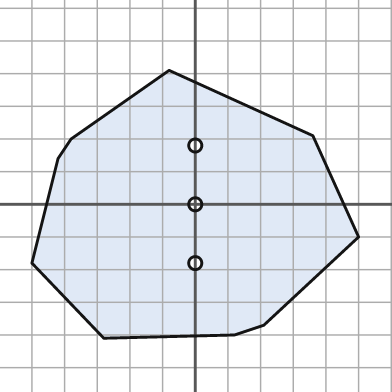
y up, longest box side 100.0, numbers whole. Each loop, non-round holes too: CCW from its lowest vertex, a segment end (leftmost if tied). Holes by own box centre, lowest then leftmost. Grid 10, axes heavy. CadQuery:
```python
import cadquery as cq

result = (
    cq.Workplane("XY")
    .moveTo(-28.0, -41.0)
    .lineTo(12.0, -40.0)
    .lineTo(21.0, -37.0)
    .lineTo(50.0, -10.0)
    .lineTo(36.0, 21.0)
    .lineTo(-8.0, 41.0)
    .lineTo(-38.0, 20.0)
    .lineTo(-42.0, 14.0)
    .lineTo(-50.0, -18.0)
    .close()
    .moveTo(0.0, -18.0)
    .circle(2.0)
    .moveTo(0.0, 0.0)
    .circle(2.0)
    .moveTo(0.0, 18.0)
    .circle(2.0)
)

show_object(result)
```